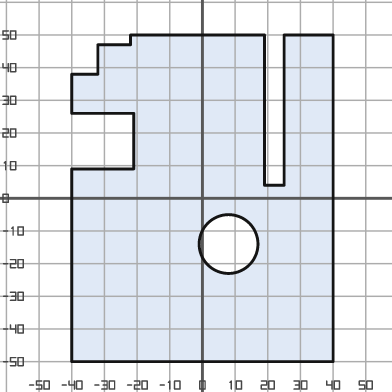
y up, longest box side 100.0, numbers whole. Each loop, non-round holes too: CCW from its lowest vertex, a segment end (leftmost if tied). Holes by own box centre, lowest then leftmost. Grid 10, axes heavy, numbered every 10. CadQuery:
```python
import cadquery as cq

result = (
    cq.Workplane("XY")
    .moveTo(-40.0, -50.0)
    .lineTo(40.0, -50.0)
    .lineTo(40.0, 50.0)
    .lineTo(25.0, 50.0)
    .lineTo(25.0, 4.0)
    .lineTo(19.0, 4.0)
    .lineTo(19.0, 50.0)
    .lineTo(-22.0, 50.0)
    .lineTo(-22.0, 47.0)
    .lineTo(-32.0, 47.0)
    .lineTo(-32.0, 38.0)
    .lineTo(-40.0, 38.0)
    .lineTo(-40.0, 26.0)
    .lineTo(-21.0, 26.0)
    .lineTo(-21.0, 9.0)
    .lineTo(-40.0, 9.0)
    .close()
    .moveTo(8.0, -14.0)
    .circle(9.0)
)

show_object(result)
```